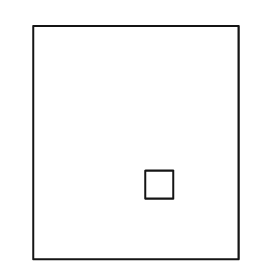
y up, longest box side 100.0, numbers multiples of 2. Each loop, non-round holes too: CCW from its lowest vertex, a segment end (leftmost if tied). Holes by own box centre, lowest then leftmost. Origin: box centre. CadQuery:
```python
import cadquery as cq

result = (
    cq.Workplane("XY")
    .moveTo(-44.0, -50.0)
    .lineTo(44.0, -50.0)
    .lineTo(44.0, 50.0)
    .lineTo(-44.0, 50.0)
    .close()
    .moveTo(4.0, -24.0)
    .lineTo(16.0, -24.0)
    .lineTo(16.0, -12.0)
    .lineTo(4.0, -12.0)
    .close()
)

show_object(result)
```